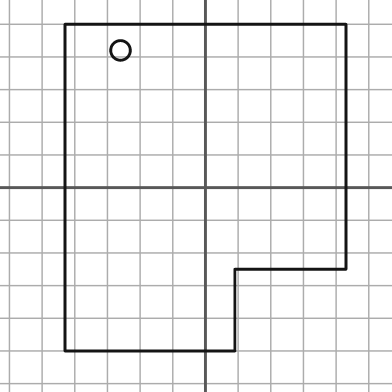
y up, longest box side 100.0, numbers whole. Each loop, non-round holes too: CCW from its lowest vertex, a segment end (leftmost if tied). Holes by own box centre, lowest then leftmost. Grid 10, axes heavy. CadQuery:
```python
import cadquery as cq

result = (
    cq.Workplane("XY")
    .moveTo(-43.0, -50.0)
    .lineTo(9.0, -50.0)
    .lineTo(9.0, -25.0)
    .lineTo(43.0, -25.0)
    .lineTo(43.0, 50.0)
    .lineTo(-43.0, 50.0)
    .close()
    .moveTo(-26.0, 42.0)
    .circle(3.0)
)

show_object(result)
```